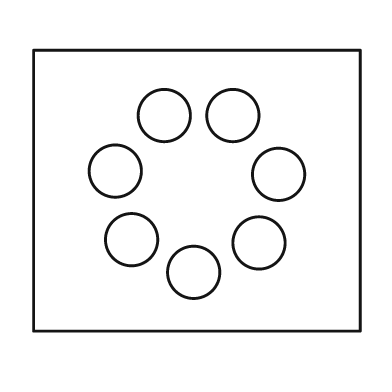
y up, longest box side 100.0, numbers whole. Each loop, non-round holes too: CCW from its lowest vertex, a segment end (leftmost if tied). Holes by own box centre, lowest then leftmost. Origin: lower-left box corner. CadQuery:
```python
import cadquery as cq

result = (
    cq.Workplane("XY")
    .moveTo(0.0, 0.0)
    .lineTo(100.0, 0.0)
    .lineTo(100.0, 86.0)
    .lineTo(0.0, 86.0)
    .close()
    .moveTo(49.0, 18.0)
    .circle(8.0)
    .moveTo(69.0, 27.0)
    .circle(8.0)
    .moveTo(30.0, 28.0)
    .circle(8.0)
    .moveTo(75.0, 48.0)
    .circle(8.0)
    .moveTo(25.0, 49.0)
    .circle(8.0)
    .moveTo(40.0, 66.0)
    .circle(8.0)
    .moveTo(61.0, 66.0)
    .circle(8.0)
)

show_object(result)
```